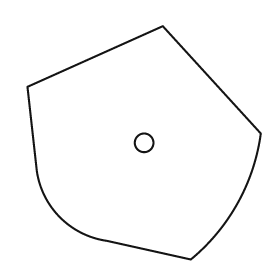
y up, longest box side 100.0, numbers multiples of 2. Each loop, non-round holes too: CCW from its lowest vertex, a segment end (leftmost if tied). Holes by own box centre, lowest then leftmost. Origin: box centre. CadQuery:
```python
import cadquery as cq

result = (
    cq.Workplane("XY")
    .moveTo(20.0, -50.0)
    .threePointArc((40.0, -26.0), (50.0, 4.0))
    .lineTo(8.0, 50.0)
    .lineTo(-50.0, 24.0)
    .lineTo(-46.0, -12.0)
    .threePointArc((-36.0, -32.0), (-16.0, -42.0))
    .close()
    .moveTo(0.0, 0.0)
    .circle(4.0)
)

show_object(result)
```